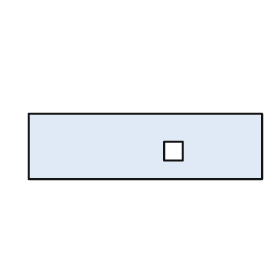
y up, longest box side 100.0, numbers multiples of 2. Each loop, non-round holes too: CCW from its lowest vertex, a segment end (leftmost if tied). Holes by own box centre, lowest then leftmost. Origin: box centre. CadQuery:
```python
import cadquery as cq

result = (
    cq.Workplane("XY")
    .moveTo(-50.0, -14.0)
    .lineTo(50.0, -14.0)
    .lineTo(50.0, 14.0)
    .lineTo(-50.0, 14.0)
    .close()
    .moveTo(8.0, -6.0)
    .lineTo(16.0, -6.0)
    .lineTo(16.0, 2.0)
    .lineTo(8.0, 2.0)
    .close()
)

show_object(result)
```